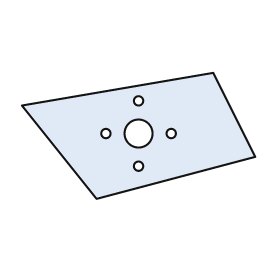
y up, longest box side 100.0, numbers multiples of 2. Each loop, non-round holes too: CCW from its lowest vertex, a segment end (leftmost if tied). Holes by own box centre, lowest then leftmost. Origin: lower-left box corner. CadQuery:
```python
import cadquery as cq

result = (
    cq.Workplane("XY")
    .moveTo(32.0, 0.0)
    .lineTo(100.0, 18.0)
    .lineTo(82.0, 54.0)
    .lineTo(0.0, 40.0)
    .close()
    .moveTo(50.0, 14.0)
    .circle(2.0)
    .moveTo(36.0, 28.0)
    .circle(2.0)
    .moveTo(50.0, 28.0)
    .circle(6.0)
    .moveTo(64.0, 28.0)
    .circle(2.0)
    .moveTo(50.0, 42.0)
    .circle(2.0)
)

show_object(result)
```